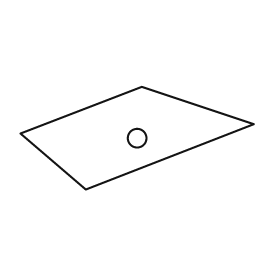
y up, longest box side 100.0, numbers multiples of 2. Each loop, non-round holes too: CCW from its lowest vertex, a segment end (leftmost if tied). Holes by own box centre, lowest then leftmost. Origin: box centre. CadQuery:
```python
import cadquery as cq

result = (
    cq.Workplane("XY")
    .moveTo(-22.0, -22.0)
    .lineTo(50.0, 6.0)
    .lineTo(2.0, 22.0)
    .lineTo(-50.0, 2.0)
    .close()
    .moveTo(0.0, 0.0)
    .circle(4.0)
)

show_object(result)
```